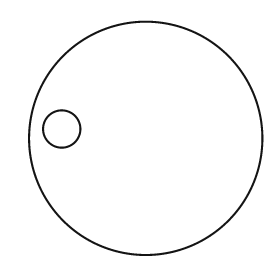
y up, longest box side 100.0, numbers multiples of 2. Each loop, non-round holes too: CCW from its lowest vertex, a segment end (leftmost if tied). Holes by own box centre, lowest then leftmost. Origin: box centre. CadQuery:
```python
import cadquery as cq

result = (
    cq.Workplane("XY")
    .moveTo(0.0, 0.0)
    .circle(50.0)
    .moveTo(-36.0, 4.0)
    .circle(8.0)
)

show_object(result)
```